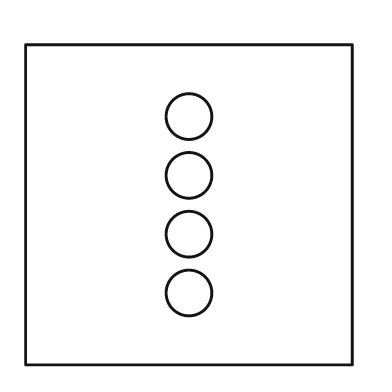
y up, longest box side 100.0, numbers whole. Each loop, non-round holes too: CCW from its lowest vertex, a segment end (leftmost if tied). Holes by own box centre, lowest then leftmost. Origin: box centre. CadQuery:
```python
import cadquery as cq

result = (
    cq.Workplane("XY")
    .moveTo(-50.0, -49.0)
    .lineTo(50.0, -49.0)
    .lineTo(50.0, 49.0)
    .lineTo(-50.0, 49.0)
    .close()
    .moveTo(0.0, -27.0)
    .circle(7.0)
    .moveTo(0.0, -9.0)
    .circle(7.0)
    .moveTo(0.0, 9.0)
    .circle(7.0)
    .moveTo(0.0, 27.0)
    .circle(7.0)
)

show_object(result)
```